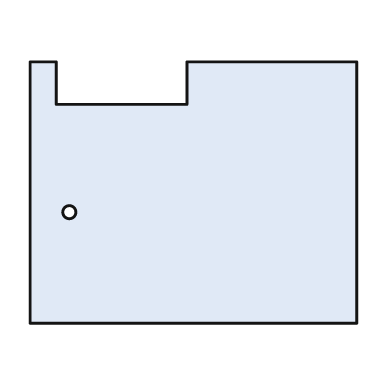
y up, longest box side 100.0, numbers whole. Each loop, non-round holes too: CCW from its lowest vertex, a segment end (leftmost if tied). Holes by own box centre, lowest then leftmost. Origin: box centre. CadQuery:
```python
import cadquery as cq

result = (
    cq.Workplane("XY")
    .moveTo(-50.0, -40.0)
    .lineTo(50.0, -40.0)
    .lineTo(50.0, 40.0)
    .lineTo(-2.0, 40.0)
    .lineTo(-2.0, 27.0)
    .lineTo(-42.0, 27.0)
    .lineTo(-42.0, 40.0)
    .lineTo(-50.0, 40.0)
    .close()
    .moveTo(-38.0, -6.0)
    .circle(2.0)
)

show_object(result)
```